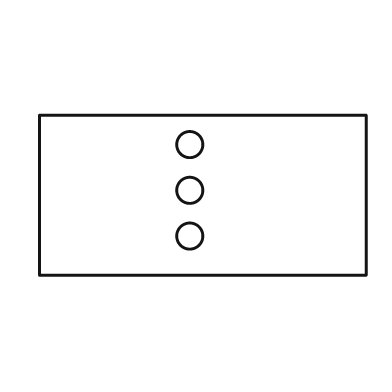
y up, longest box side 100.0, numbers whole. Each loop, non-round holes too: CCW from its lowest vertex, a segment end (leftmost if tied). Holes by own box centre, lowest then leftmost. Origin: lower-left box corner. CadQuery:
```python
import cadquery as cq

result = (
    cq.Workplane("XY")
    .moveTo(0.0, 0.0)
    .lineTo(100.0, 0.0)
    .lineTo(100.0, 49.0)
    .lineTo(0.0, 49.0)
    .close()
    .moveTo(46.0, 12.0)
    .circle(4.0)
    .moveTo(46.0, 26.0)
    .circle(4.0)
    .moveTo(46.0, 40.0)
    .circle(4.0)
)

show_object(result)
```